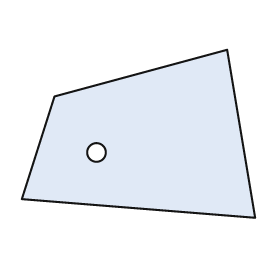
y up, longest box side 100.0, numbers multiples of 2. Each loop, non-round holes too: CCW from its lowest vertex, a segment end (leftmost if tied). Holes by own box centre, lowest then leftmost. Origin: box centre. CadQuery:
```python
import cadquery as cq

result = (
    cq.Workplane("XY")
    .moveTo(50.0, -36.0)
    .lineTo(38.0, 36.0)
    .lineTo(-36.0, 16.0)
    .lineTo(-50.0, -28.0)
    .close()
    .moveTo(-18.0, -8.0)
    .circle(4.0)
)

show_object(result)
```